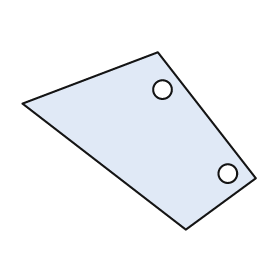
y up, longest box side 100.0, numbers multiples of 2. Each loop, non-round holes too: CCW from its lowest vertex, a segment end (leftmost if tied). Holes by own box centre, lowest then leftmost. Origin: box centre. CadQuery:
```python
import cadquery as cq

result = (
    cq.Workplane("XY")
    .moveTo(20.0, -38.0)
    .lineTo(50.0, -16.0)
    .lineTo(8.0, 38.0)
    .lineTo(-50.0, 16.0)
    .close()
    .moveTo(38.0, -14.0)
    .circle(4.0)
    .moveTo(10.0, 22.0)
    .circle(4.0)
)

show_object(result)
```